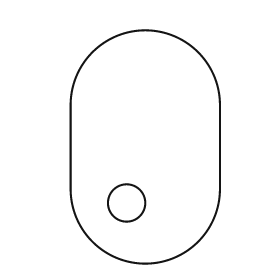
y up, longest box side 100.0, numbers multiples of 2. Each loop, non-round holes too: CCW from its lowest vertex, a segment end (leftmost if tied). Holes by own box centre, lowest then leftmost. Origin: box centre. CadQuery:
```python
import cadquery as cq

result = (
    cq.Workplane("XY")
    .moveTo(-32.0, -18.0)
    .threePointArc((0.0, -50.0), (32.0, -18.0))
    .lineTo(32.0, 18.0)
    .threePointArc((0.0, 50.0), (-32.0, 18.0))
    .close()
    .moveTo(-8.0, -24.0)
    .circle(8.0)
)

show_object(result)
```